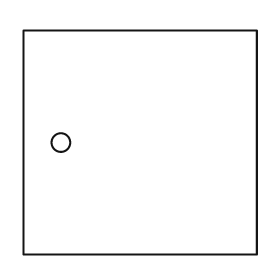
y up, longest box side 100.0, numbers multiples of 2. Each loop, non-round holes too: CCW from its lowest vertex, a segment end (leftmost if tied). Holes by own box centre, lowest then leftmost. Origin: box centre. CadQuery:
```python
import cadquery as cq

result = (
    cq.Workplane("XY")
    .moveTo(-50.0, -48.0)
    .lineTo(50.0, -48.0)
    .lineTo(50.0, 48.0)
    .lineTo(-50.0, 48.0)
    .close()
    .moveTo(-34.0, 0.0)
    .circle(4.0)
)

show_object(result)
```